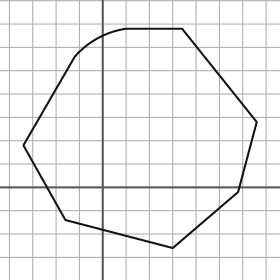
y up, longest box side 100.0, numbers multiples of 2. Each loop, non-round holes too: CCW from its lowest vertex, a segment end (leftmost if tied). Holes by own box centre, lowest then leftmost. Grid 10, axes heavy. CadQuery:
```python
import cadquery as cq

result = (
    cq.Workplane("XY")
    .moveTo(30.0, -26.0)
    .lineTo(58.0, -2.0)
    .lineTo(66.0, 28.0)
    .lineTo(34.0, 68.0)
    .lineTo(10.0, 68.0)
    .threePointArc((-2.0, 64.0), (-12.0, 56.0))
    .lineTo(-34.0, 18.0)
    .lineTo(-16.0, -14.0)
    .close()
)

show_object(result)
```